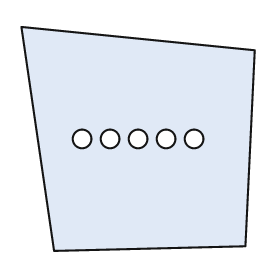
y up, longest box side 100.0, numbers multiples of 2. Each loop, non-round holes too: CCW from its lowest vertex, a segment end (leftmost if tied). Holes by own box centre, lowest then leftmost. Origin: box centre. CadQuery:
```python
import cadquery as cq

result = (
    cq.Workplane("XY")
    .moveTo(-36.0, -48.0)
    .lineTo(46.0, -46.0)
    .lineTo(50.0, 38.0)
    .lineTo(-50.0, 48.0)
    .close()
    .moveTo(-24.0, 0.0)
    .circle(4.0)
    .moveTo(-12.0, 0.0)
    .circle(4.0)
    .moveTo(0.0, 0.0)
    .circle(4.0)
    .moveTo(12.0, 0.0)
    .circle(4.0)
    .moveTo(24.0, 0.0)
    .circle(4.0)
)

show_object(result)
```